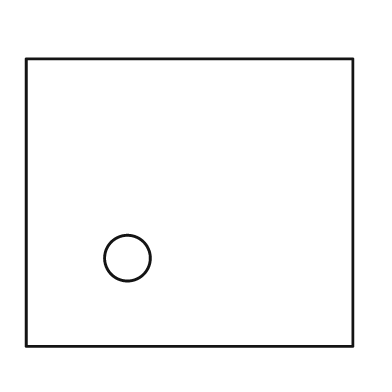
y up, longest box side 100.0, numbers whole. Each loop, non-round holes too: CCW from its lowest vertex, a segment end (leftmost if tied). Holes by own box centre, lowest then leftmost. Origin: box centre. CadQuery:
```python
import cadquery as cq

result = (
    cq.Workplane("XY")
    .moveTo(-50.0, -44.0)
    .lineTo(50.0, -44.0)
    .lineTo(50.0, 44.0)
    .lineTo(-50.0, 44.0)
    .close()
    .moveTo(-19.0, -17.0)
    .circle(7.0)
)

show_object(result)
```